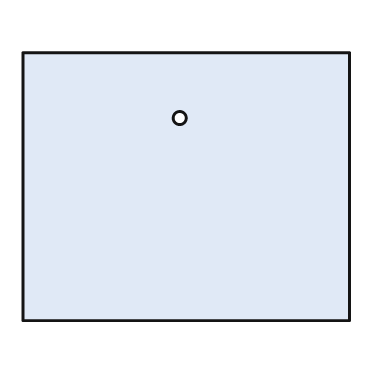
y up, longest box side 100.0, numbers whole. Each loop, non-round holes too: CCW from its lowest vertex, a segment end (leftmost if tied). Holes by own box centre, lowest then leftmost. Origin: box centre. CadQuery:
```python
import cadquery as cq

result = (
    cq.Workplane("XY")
    .moveTo(-50.0, -41.0)
    .lineTo(50.0, -41.0)
    .lineTo(50.0, 41.0)
    .lineTo(-50.0, 41.0)
    .close()
    .moveTo(-2.0, 21.0)
    .circle(2.0)
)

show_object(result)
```